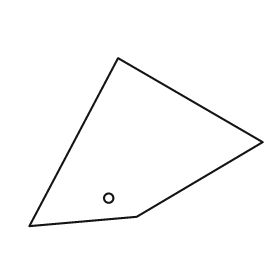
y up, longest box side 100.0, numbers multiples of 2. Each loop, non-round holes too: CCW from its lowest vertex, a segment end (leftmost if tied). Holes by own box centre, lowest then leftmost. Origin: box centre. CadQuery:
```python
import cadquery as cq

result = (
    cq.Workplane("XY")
    .moveTo(-50.0, -36.0)
    .lineTo(-4.0, -32.0)
    .lineTo(50.0, 0.0)
    .lineTo(-12.0, 36.0)
    .close()
    .moveTo(-16.0, -24.0)
    .circle(2.0)
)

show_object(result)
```